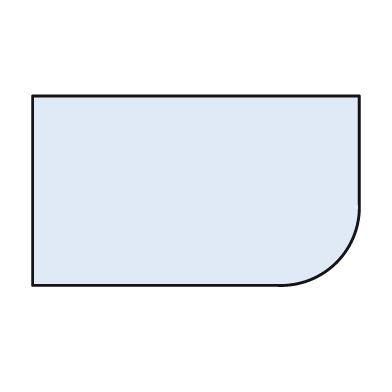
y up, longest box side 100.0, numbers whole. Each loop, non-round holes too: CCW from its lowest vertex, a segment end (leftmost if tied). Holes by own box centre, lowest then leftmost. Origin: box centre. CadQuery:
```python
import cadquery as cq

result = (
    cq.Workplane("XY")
    .moveTo(-50.0, -29.0)
    .lineTo(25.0, -29.0)
    .threePointArc((43.0, -22.0), (50.0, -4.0))
    .lineTo(50.0, 29.0)
    .lineTo(-50.0, 29.0)
    .close()
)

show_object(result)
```